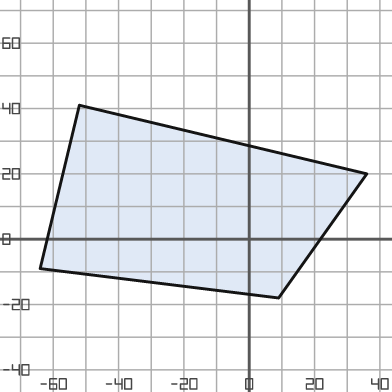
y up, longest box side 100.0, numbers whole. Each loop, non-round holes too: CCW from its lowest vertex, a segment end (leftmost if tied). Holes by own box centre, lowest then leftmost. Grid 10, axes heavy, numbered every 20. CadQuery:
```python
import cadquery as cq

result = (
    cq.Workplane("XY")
    .moveTo(9.0, -18.0)
    .lineTo(36.0, 20.0)
    .lineTo(-52.0, 41.0)
    .lineTo(-64.0, -9.0)
    .close()
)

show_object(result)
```